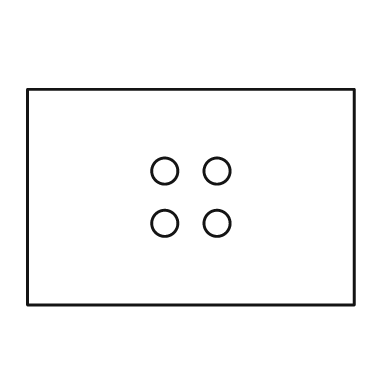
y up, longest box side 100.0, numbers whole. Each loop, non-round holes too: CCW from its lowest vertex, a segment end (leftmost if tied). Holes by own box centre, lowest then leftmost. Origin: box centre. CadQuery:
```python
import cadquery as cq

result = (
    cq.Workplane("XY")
    .moveTo(-50.0, -33.0)
    .lineTo(50.0, -33.0)
    .lineTo(50.0, 33.0)
    .lineTo(-50.0, 33.0)
    .close()
    .moveTo(-8.0, -8.0)
    .circle(4.0)
    .moveTo(8.0, -8.0)
    .circle(4.0)
    .moveTo(-8.0, 8.0)
    .circle(4.0)
    .moveTo(8.0, 8.0)
    .circle(4.0)
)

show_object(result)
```